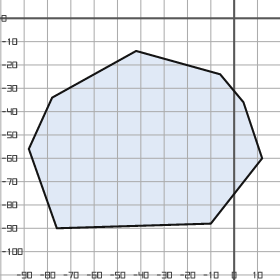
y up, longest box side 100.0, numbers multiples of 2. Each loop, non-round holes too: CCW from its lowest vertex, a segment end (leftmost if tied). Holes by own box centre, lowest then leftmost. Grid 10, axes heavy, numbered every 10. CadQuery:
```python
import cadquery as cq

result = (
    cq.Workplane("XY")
    .moveTo(-76.0, -90.0)
    .lineTo(-10.0, -88.0)
    .lineTo(12.0, -60.0)
    .lineTo(4.0, -36.0)
    .lineTo(-6.0, -24.0)
    .lineTo(-42.0, -14.0)
    .lineTo(-78.0, -34.0)
    .lineTo(-88.0, -56.0)
    .close()
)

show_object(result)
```